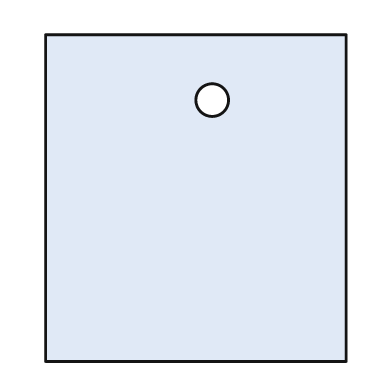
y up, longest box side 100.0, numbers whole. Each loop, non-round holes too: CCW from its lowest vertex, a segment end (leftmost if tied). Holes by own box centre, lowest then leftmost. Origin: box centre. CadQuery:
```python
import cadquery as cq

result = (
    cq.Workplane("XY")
    .moveTo(-46.0, -50.0)
    .lineTo(46.0, -50.0)
    .lineTo(46.0, 50.0)
    .lineTo(-46.0, 50.0)
    .close()
    .moveTo(5.0, 30.0)
    .circle(5.0)
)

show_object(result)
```